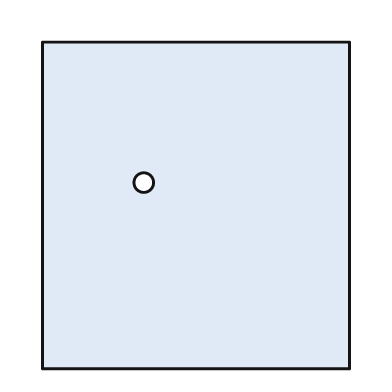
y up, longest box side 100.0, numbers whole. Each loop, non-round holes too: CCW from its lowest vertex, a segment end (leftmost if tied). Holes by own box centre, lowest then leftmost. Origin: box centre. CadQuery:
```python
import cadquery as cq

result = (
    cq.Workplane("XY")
    .moveTo(-47.0, -50.0)
    .lineTo(47.0, -50.0)
    .lineTo(47.0, 50.0)
    .lineTo(-47.0, 50.0)
    .close()
    .moveTo(-16.0, 7.0)
    .circle(3.0)
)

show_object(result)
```